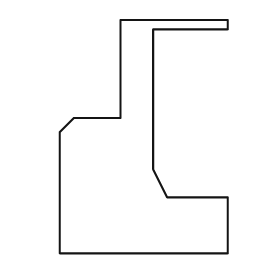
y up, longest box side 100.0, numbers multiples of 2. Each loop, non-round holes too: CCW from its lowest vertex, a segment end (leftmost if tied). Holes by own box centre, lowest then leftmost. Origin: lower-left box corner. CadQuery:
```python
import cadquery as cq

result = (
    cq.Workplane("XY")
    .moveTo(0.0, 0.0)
    .lineTo(72.0, 0.0)
    .lineTo(72.0, 24.0)
    .lineTo(46.0, 24.0)
    .lineTo(40.0, 36.0)
    .lineTo(40.0, 96.0)
    .lineTo(72.0, 96.0)
    .lineTo(72.0, 100.0)
    .lineTo(26.0, 100.0)
    .lineTo(26.0, 58.0)
    .lineTo(6.0, 58.0)
    .lineTo(0.0, 52.0)
    .close()
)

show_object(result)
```